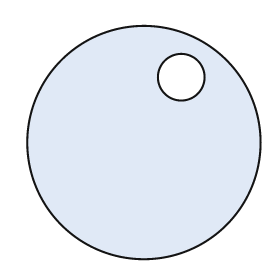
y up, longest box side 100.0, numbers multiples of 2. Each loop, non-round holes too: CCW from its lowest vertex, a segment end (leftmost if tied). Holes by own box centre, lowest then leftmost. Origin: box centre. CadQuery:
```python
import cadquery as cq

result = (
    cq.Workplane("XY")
    .moveTo(0.0, 0.0)
    .circle(50.0)
    .moveTo(16.0, 28.0)
    .circle(10.0)
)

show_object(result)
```